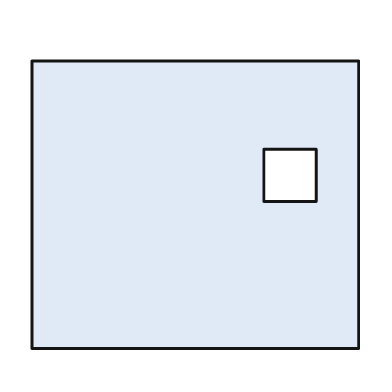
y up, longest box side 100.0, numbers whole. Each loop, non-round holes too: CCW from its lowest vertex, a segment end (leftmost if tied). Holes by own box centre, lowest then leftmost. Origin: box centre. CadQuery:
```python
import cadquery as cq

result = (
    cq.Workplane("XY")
    .moveTo(-50.0, -44.0)
    .lineTo(50.0, -44.0)
    .lineTo(50.0, 44.0)
    .lineTo(-50.0, 44.0)
    .close()
    .moveTo(21.0, 1.0)
    .lineTo(37.0, 1.0)
    .lineTo(37.0, 17.0)
    .lineTo(21.0, 17.0)
    .close()
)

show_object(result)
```